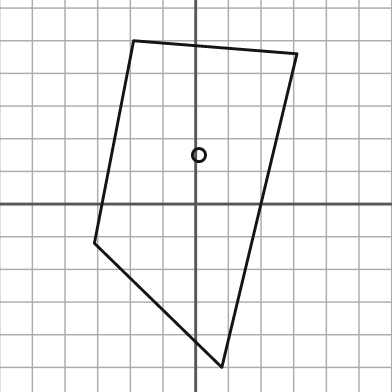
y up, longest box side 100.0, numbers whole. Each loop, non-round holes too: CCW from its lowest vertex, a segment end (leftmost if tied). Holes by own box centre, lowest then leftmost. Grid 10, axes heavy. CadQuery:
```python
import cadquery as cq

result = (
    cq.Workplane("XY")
    .moveTo(8.0, -50.0)
    .lineTo(31.0, 46.0)
    .lineTo(-19.0, 50.0)
    .lineTo(-31.0, -12.0)
    .close()
    .moveTo(1.0, 15.0)
    .circle(2.0)
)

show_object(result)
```